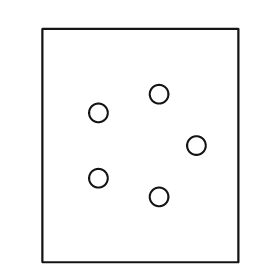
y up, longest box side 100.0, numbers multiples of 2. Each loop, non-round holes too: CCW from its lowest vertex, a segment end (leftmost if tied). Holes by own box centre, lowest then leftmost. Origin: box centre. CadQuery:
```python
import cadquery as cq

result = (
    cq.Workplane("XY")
    .moveTo(-42.0, -50.0)
    .lineTo(42.0, -50.0)
    .lineTo(42.0, 50.0)
    .lineTo(-42.0, 50.0)
    .close()
    .moveTo(8.0, -22.0)
    .circle(4.0)
    .moveTo(-18.0, -14.0)
    .circle(4.0)
    .moveTo(24.0, 0.0)
    .circle(4.0)
    .moveTo(-18.0, 14.0)
    .circle(4.0)
    .moveTo(8.0, 22.0)
    .circle(4.0)
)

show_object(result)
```